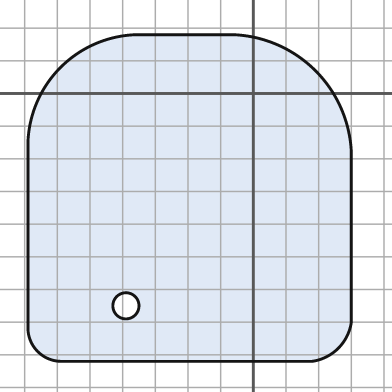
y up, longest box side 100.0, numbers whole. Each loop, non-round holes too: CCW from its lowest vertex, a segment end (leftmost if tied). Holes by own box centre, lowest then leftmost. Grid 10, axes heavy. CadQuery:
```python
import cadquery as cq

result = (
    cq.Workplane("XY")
    .moveTo(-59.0, -82.0)
    .lineTo(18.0, -82.0)
    .threePointArc((26.0, -78.0), (30.0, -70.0))
    .lineTo(30.0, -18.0)
    .threePointArc((19.0, 7.0), (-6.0, 18.0))
    .lineTo(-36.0, 18.0)
    .threePointArc((-59.0, 8.0), (-69.0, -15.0))
    .lineTo(-69.0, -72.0)
    .threePointArc((-66.0, -79.0), (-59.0, -82.0))
    .close()
    .moveTo(-39.0, -65.0)
    .circle(4.0)
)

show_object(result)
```